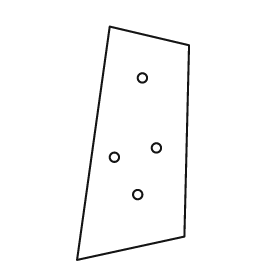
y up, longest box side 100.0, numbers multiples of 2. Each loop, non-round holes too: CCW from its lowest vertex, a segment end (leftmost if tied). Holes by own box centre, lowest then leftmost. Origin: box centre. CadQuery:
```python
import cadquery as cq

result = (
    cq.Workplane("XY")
    .moveTo(-24.0, -50.0)
    .lineTo(22.0, -40.0)
    .lineTo(24.0, 42.0)
    .lineTo(-10.0, 50.0)
    .close()
    .moveTo(2.0, -22.0)
    .circle(2.0)
    .moveTo(-8.0, -6.0)
    .circle(2.0)
    .moveTo(10.0, -2.0)
    .circle(2.0)
    .moveTo(4.0, 28.0)
    .circle(2.0)
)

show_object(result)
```